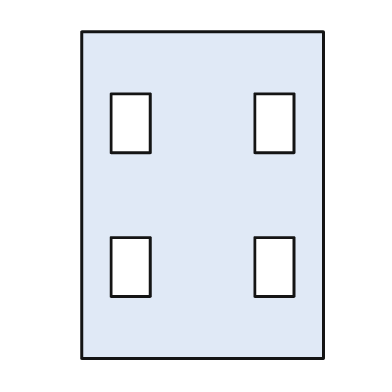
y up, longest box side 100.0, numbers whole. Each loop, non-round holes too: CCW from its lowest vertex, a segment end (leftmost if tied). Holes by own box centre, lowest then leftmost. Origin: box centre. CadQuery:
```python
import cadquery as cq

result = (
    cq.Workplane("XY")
    .moveTo(-37.0, -50.0)
    .lineTo(37.0, -50.0)
    .lineTo(37.0, 50.0)
    .lineTo(-37.0, 50.0)
    .close()
    .moveTo(-28.0, -31.0)
    .lineTo(-16.0, -31.0)
    .lineTo(-16.0, -13.0)
    .lineTo(-28.0, -13.0)
    .close()
    .moveTo(16.0, -31.0)
    .lineTo(28.0, -31.0)
    .lineTo(28.0, -13.0)
    .lineTo(16.0, -13.0)
    .close()
    .moveTo(-28.0, 13.0)
    .lineTo(-16.0, 13.0)
    .lineTo(-16.0, 31.0)
    .lineTo(-28.0, 31.0)
    .close()
    .moveTo(16.0, 13.0)
    .lineTo(28.0, 13.0)
    .lineTo(28.0, 31.0)
    .lineTo(16.0, 31.0)
    .close()
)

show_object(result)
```